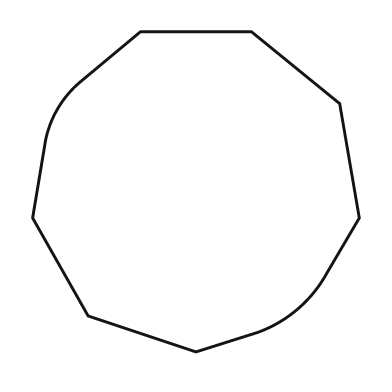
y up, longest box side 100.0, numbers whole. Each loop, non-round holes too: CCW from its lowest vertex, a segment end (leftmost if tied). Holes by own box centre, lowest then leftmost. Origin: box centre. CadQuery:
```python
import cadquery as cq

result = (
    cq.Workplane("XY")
    .moveTo(0.0, -49.0)
    .lineTo(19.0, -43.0)
    .threePointArc((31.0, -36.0), (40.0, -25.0))
    .lineTo(50.0, -8.0)
    .lineTo(44.0, 27.0)
    .lineTo(17.0, 49.0)
    .lineTo(-17.0, 49.0)
    .lineTo(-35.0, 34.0)
    .threePointArc((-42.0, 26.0), (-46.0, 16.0))
    .lineTo(-50.0, -8.0)
    .lineTo(-33.0, -38.0)
    .close()
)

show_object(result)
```